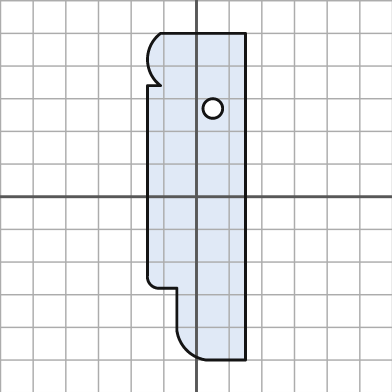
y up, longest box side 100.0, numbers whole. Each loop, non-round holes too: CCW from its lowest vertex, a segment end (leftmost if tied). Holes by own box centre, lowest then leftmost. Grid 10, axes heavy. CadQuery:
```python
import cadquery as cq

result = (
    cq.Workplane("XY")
    .moveTo(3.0, -50.0)
    .lineTo(15.0, -50.0)
    .lineTo(15.0, 50.0)
    .lineTo(-11.0, 50.0)
    .threePointArc((-15.0, 42.0), (-11.0, 34.0))
    .lineTo(-15.0, 34.0)
    .lineTo(-15.0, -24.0)
    .threePointArc((-14.0, -27.0), (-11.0, -28.0))
    .lineTo(-6.0, -28.0)
    .lineTo(-6.0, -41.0)
    .threePointArc((-3.0, -47.0), (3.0, -50.0))
    .close()
    .moveTo(5.0, 27.0)
    .circle(3.0)
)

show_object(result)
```